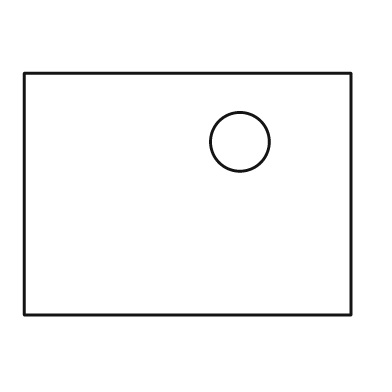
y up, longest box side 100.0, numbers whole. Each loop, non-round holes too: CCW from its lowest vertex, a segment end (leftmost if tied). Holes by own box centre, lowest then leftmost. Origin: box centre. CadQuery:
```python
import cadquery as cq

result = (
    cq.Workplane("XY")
    .moveTo(-50.0, -37.0)
    .lineTo(50.0, -37.0)
    .lineTo(50.0, 37.0)
    .lineTo(-50.0, 37.0)
    .close()
    .moveTo(16.0, 16.0)
    .circle(9.0)
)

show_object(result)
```